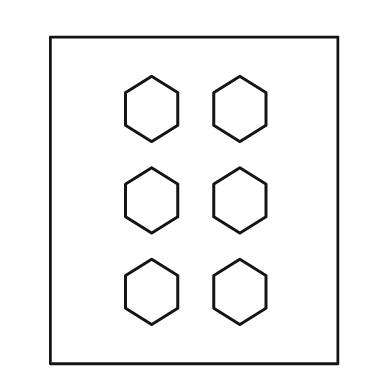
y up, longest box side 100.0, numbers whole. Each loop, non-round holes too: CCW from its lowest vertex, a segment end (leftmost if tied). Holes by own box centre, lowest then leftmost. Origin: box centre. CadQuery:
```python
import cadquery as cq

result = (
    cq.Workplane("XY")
    .moveTo(-44.0, -50.0)
    .lineTo(44.0, -50.0)
    .lineTo(44.0, 50.0)
    .lineTo(-44.0, 50.0)
    .close()
    .moveTo(-13.0, -38.0)
    .lineTo(-5.0, -33.0)
    .lineTo(-5.0, -23.0)
    .lineTo(-13.0, -18.0)
    .lineTo(-21.0, -23.0)
    .lineTo(-21.0, -33.0)
    .close()
    .moveTo(14.0, -38.0)
    .lineTo(22.0, -33.0)
    .lineTo(22.0, -23.0)
    .lineTo(14.0, -18.0)
    .lineTo(6.0, -23.0)
    .lineTo(6.0, -33.0)
    .close()
    .moveTo(-13.0, -10.0)
    .lineTo(-5.0, -5.0)
    .lineTo(-5.0, 5.0)
    .lineTo(-13.0, 10.0)
    .lineTo(-21.0, 5.0)
    .lineTo(-21.0, -5.0)
    .close()
    .moveTo(14.0, -10.0)
    .lineTo(22.0, -5.0)
    .lineTo(22.0, 5.0)
    .lineTo(14.0, 10.0)
    .lineTo(6.0, 5.0)
    .lineTo(6.0, -5.0)
    .close()
    .moveTo(-13.0, 18.0)
    .lineTo(-5.0, 23.0)
    .lineTo(-5.0, 33.0)
    .lineTo(-13.0, 38.0)
    .lineTo(-21.0, 33.0)
    .lineTo(-21.0, 23.0)
    .close()
    .moveTo(14.0, 18.0)
    .lineTo(22.0, 23.0)
    .lineTo(22.0, 33.0)
    .lineTo(14.0, 38.0)
    .lineTo(6.0, 33.0)
    .lineTo(6.0, 23.0)
    .close()
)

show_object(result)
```